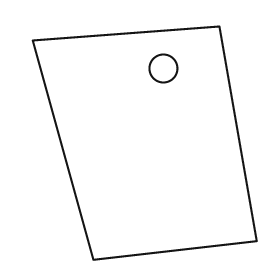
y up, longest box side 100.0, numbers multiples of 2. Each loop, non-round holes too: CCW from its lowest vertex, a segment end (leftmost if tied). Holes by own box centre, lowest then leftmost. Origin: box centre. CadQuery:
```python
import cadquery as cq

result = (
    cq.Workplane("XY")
    .moveTo(-22.0, -50.0)
    .lineTo(48.0, -42.0)
    .lineTo(32.0, 50.0)
    .lineTo(-48.0, 44.0)
    .close()
    .moveTo(8.0, 32.0)
    .circle(6.0)
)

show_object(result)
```